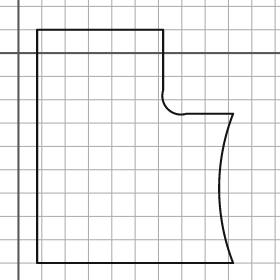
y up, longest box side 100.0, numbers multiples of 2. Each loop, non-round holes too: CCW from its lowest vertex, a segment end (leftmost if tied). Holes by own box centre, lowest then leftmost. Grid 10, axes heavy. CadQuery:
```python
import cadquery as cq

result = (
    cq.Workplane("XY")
    .moveTo(8.0, -90.0)
    .lineTo(92.0, -90.0)
    .threePointArc((86.0, -58.0), (92.0, -26.0))
    .lineTo(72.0, -26.0)
    .threePointArc((64.0, -24.0), (62.0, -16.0))
    .lineTo(62.0, 10.0)
    .lineTo(8.0, 10.0)
    .close()
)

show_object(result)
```